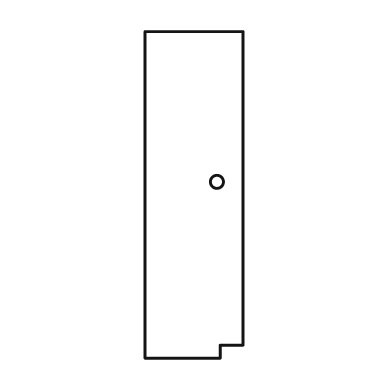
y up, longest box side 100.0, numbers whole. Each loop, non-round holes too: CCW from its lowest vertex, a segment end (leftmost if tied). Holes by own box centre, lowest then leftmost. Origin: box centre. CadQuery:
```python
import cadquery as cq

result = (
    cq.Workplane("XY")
    .moveTo(-15.0, -50.0)
    .lineTo(8.0, -50.0)
    .lineTo(8.0, -46.0)
    .lineTo(15.0, -46.0)
    .lineTo(15.0, 50.0)
    .lineTo(-15.0, 50.0)
    .close()
    .moveTo(7.0, 4.0)
    .circle(2.0)
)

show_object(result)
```